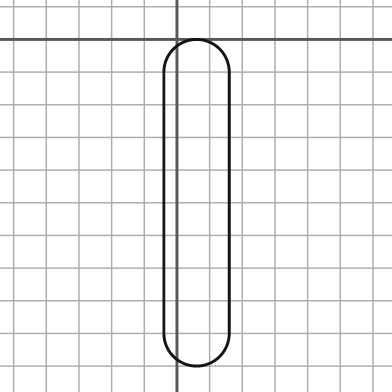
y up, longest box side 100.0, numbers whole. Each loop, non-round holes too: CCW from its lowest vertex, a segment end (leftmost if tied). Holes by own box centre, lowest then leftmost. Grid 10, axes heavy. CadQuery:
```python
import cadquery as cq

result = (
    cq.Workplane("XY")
    .moveTo(-4.0, -90.0)
    .threePointArc((6.0, -100.0), (16.0, -90.0))
    .lineTo(16.0, -10.0)
    .threePointArc((6.0, 0.0), (-4.0, -10.0))
    .close()
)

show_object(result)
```